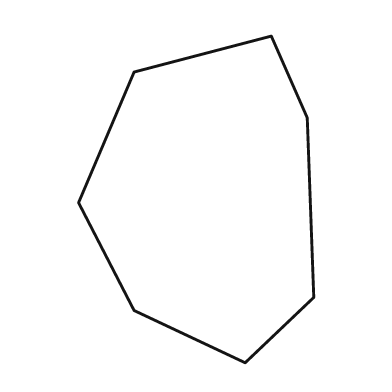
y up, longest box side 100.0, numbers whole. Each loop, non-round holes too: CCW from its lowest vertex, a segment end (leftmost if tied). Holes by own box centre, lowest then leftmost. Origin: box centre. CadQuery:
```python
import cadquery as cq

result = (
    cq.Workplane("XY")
    .moveTo(15.0, -50.0)
    .lineTo(36.0, -30.0)
    .lineTo(34.0, 25.0)
    .lineTo(23.0, 50.0)
    .lineTo(-19.0, 39.0)
    .lineTo(-36.0, -1.0)
    .lineTo(-19.0, -34.0)
    .close()
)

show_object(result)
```